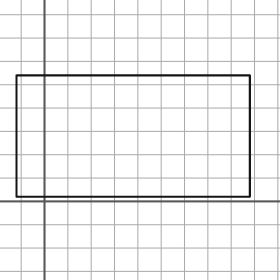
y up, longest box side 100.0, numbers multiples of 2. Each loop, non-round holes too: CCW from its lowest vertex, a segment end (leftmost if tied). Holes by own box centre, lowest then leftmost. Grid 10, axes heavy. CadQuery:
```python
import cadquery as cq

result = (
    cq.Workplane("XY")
    .moveTo(-12.0, 2.0)
    .lineTo(88.0, 2.0)
    .lineTo(88.0, 54.0)
    .lineTo(-12.0, 54.0)
    .close()
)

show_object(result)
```